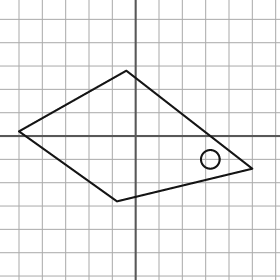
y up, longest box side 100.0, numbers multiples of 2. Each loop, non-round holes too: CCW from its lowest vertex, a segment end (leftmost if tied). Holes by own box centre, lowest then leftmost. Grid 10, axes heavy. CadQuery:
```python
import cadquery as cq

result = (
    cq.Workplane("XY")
    .moveTo(-8.0, -28.0)
    .lineTo(50.0, -14.0)
    .lineTo(-4.0, 28.0)
    .lineTo(-50.0, 2.0)
    .close()
    .moveTo(32.0, -10.0)
    .circle(4.0)
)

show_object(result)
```